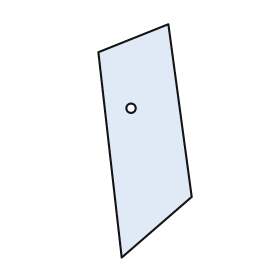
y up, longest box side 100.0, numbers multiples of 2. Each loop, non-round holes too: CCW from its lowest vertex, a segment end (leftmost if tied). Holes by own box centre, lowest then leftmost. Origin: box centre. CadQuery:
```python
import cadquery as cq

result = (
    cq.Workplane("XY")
    .moveTo(-10.0, -50.0)
    .lineTo(20.0, -24.0)
    .lineTo(10.0, 50.0)
    .lineTo(-20.0, 38.0)
    .close()
    .moveTo(-6.0, 14.0)
    .circle(2.0)
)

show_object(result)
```